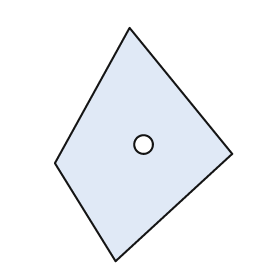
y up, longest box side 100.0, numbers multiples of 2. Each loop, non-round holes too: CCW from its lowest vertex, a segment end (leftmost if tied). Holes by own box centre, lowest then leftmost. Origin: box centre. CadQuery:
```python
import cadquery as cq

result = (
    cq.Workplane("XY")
    .moveTo(-12.0, -50.0)
    .lineTo(38.0, -4.0)
    .lineTo(-6.0, 50.0)
    .lineTo(-38.0, -8.0)
    .close()
    .moveTo(0.0, 0.0)
    .circle(4.0)
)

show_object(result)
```